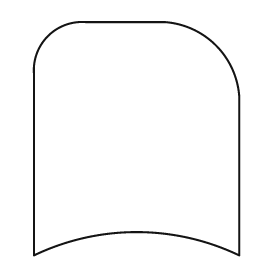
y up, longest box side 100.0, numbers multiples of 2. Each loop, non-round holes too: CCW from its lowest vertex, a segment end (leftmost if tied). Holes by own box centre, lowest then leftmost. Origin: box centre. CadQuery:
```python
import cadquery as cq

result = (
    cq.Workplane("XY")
    .moveTo(-44.0, -50.0)
    .threePointArc((0.0, -40.0), (44.0, -50.0))
    .lineTo(44.0, 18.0)
    .threePointArc((34.0, 40.0), (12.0, 50.0))
    .lineTo(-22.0, 50.0)
    .threePointArc((-38.0, 44.0), (-44.0, 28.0))
    .close()
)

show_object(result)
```